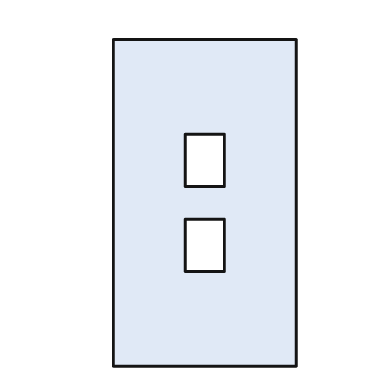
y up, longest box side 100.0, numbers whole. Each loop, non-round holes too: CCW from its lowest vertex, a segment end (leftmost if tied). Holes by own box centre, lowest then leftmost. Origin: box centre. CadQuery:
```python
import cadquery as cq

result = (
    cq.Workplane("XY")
    .moveTo(-28.0, -50.0)
    .lineTo(28.0, -50.0)
    .lineTo(28.0, 50.0)
    .lineTo(-28.0, 50.0)
    .close()
    .moveTo(-6.0, -21.0)
    .lineTo(6.0, -21.0)
    .lineTo(6.0, -5.0)
    .lineTo(-6.0, -5.0)
    .close()
    .moveTo(-6.0, 5.0)
    .lineTo(6.0, 5.0)
    .lineTo(6.0, 21.0)
    .lineTo(-6.0, 21.0)
    .close()
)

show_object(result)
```